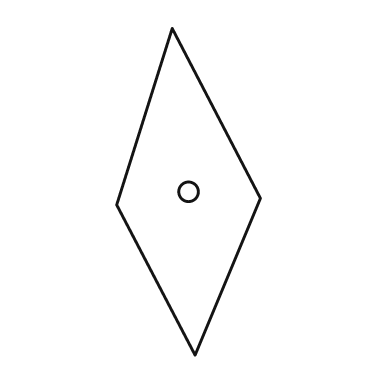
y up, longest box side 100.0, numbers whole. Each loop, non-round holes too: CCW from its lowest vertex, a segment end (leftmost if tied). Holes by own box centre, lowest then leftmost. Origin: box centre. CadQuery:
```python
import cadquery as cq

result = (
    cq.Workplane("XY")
    .moveTo(2.0, -50.0)
    .lineTo(22.0, -2.0)
    .lineTo(-5.0, 50.0)
    .lineTo(-22.0, -4.0)
    .close()
    .moveTo(0.0, 0.0)
    .circle(3.0)
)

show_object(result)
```